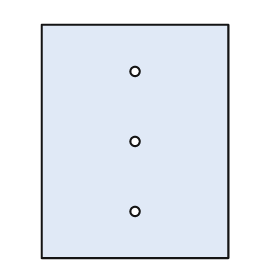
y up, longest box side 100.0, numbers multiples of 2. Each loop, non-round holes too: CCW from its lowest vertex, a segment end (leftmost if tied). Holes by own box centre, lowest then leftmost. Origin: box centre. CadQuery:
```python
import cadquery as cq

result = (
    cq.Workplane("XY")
    .moveTo(-40.0, -50.0)
    .lineTo(40.0, -50.0)
    .lineTo(40.0, 50.0)
    .lineTo(-40.0, 50.0)
    .close()
    .moveTo(0.0, -30.0)
    .circle(2.0)
    .moveTo(0.0, 0.0)
    .circle(2.0)
    .moveTo(0.0, 30.0)
    .circle(2.0)
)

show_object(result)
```